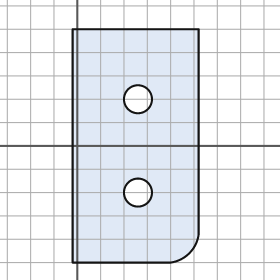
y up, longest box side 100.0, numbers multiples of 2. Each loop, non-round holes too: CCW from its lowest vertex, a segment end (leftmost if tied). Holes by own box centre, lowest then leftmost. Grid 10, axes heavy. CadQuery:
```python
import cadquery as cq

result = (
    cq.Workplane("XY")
    .moveTo(-2.0, -50.0)
    .lineTo(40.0, -50.0)
    .threePointArc((48.0, -46.0), (52.0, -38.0))
    .lineTo(52.0, 50.0)
    .lineTo(-2.0, 50.0)
    .close()
    .moveTo(26.0, -20.0)
    .circle(6.0)
    .moveTo(26.0, 20.0)
    .circle(6.0)
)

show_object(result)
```